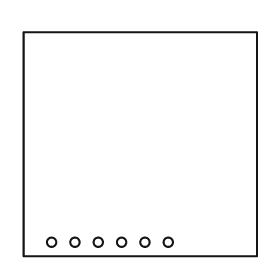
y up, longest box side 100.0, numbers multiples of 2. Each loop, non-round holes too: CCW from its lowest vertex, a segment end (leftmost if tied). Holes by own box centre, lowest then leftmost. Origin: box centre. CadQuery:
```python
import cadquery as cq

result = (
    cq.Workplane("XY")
    .moveTo(-50.0, -48.0)
    .lineTo(50.0, -48.0)
    .lineTo(50.0, 48.0)
    .lineTo(-50.0, 48.0)
    .close()
    .moveTo(-38.0, -42.0)
    .circle(2.0)
    .moveTo(-28.0, -42.0)
    .circle(2.0)
    .moveTo(-18.0, -42.0)
    .circle(2.0)
    .moveTo(-8.0, -42.0)
    .circle(2.0)
    .moveTo(2.0, -42.0)
    .circle(2.0)
    .moveTo(12.0, -42.0)
    .circle(2.0)
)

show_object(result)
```